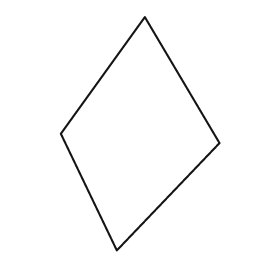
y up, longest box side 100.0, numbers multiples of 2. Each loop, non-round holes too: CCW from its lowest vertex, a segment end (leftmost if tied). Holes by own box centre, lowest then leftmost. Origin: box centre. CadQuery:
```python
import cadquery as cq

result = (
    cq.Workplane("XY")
    .moveTo(-10.0, -50.0)
    .lineTo(34.0, -4.0)
    .lineTo(2.0, 50.0)
    .lineTo(-34.0, 0.0)
    .close()
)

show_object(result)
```